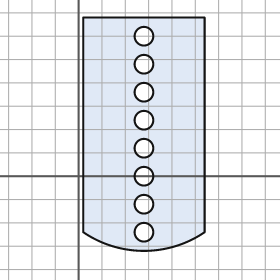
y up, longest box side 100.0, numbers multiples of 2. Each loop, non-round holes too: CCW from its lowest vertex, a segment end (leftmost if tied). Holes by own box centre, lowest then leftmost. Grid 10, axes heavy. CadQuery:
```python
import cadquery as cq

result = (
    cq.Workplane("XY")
    .moveTo(2.0, -24.0)
    .threePointArc((28.0, -32.0), (54.0, -24.0))
    .lineTo(54.0, 68.0)
    .lineTo(2.0, 68.0)
    .close()
    .moveTo(28.0, -24.0)
    .circle(4.0)
    .moveTo(28.0, -12.0)
    .circle(4.0)
    .moveTo(28.0, 0.0)
    .circle(4.0)
    .moveTo(28.0, 12.0)
    .circle(4.0)
    .moveTo(28.0, 24.0)
    .circle(4.0)
    .moveTo(28.0, 36.0)
    .circle(4.0)
    .moveTo(28.0, 48.0)
    .circle(4.0)
    .moveTo(28.0, 60.0)
    .circle(4.0)
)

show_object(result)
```